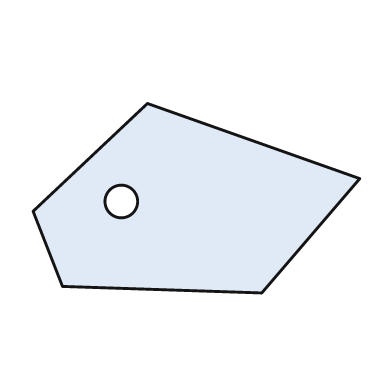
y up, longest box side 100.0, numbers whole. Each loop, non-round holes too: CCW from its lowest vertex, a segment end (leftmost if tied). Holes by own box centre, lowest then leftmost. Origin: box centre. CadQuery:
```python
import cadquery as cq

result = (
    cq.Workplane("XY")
    .moveTo(20.0, -29.0)
    .lineTo(50.0, 6.0)
    .lineTo(-15.0, 29.0)
    .lineTo(-50.0, -4.0)
    .lineTo(-41.0, -27.0)
    .close()
    .moveTo(-23.0, -1.0)
    .circle(5.0)
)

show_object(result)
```